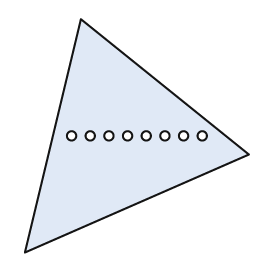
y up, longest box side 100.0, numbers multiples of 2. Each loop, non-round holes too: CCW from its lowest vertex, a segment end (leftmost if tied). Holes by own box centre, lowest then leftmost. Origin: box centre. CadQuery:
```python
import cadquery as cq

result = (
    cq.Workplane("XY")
    .moveTo(-48.0, -50.0)
    .lineTo(48.0, -8.0)
    .lineTo(-24.0, 50.0)
    .close()
    .moveTo(-28.0, 0.0)
    .circle(2.0)
    .moveTo(-20.0, 0.0)
    .circle(2.0)
    .moveTo(-12.0, 0.0)
    .circle(2.0)
    .moveTo(-4.0, 0.0)
    .circle(2.0)
    .moveTo(4.0, 0.0)
    .circle(2.0)
    .moveTo(12.0, 0.0)
    .circle(2.0)
    .moveTo(20.0, 0.0)
    .circle(2.0)
    .moveTo(28.0, 0.0)
    .circle(2.0)
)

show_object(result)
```